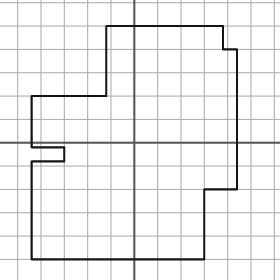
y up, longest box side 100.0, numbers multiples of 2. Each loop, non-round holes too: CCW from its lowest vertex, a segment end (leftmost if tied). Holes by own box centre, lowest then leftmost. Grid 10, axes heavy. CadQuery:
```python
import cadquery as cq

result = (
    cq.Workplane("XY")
    .moveTo(-44.0, -50.0)
    .lineTo(30.0, -50.0)
    .lineTo(30.0, -20.0)
    .lineTo(44.0, -20.0)
    .lineTo(44.0, 40.0)
    .lineTo(38.0, 40.0)
    .lineTo(38.0, 50.0)
    .lineTo(-12.0, 50.0)
    .lineTo(-12.0, 20.0)
    .lineTo(-44.0, 20.0)
    .lineTo(-44.0, -2.0)
    .lineTo(-30.0, -2.0)
    .lineTo(-30.0, -8.0)
    .lineTo(-44.0, -8.0)
    .close()
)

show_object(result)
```